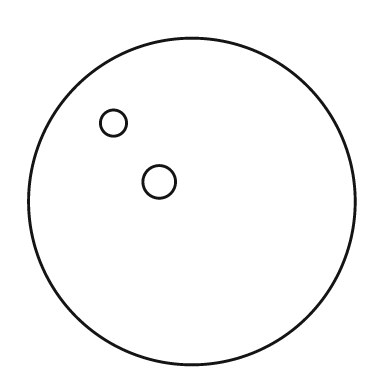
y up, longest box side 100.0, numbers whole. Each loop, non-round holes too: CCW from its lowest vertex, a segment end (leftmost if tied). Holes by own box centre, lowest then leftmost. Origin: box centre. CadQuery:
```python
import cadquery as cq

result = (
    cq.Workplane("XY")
    .moveTo(0.0, 0.0)
    .circle(50.0)
    .moveTo(-10.0, 6.0)
    .circle(5.0)
    .moveTo(-24.0, 24.0)
    .circle(4.0)
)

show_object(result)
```